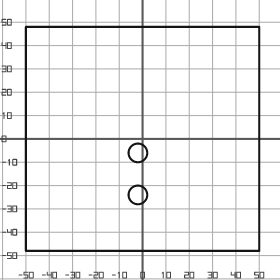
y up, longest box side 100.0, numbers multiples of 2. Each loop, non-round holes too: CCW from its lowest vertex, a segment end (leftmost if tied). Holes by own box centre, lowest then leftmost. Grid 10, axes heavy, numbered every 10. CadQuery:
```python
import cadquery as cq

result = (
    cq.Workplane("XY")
    .moveTo(-50.0, -48.0)
    .lineTo(50.0, -48.0)
    .lineTo(50.0, 48.0)
    .lineTo(-50.0, 48.0)
    .close()
    .moveTo(-2.0, -24.0)
    .circle(4.0)
    .moveTo(-2.0, -6.0)
    .circle(4.0)
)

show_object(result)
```